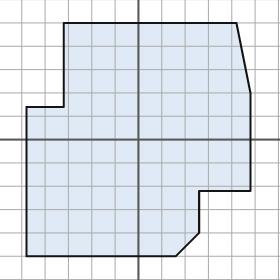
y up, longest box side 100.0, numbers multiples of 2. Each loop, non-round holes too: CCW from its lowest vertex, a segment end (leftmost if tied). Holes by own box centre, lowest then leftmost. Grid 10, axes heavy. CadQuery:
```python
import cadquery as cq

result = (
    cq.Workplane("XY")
    .moveTo(-48.0, -50.0)
    .lineTo(16.0, -50.0)
    .lineTo(26.0, -40.0)
    .lineTo(26.0, -22.0)
    .lineTo(48.0, -22.0)
    .lineTo(48.0, 20.0)
    .lineTo(42.0, 50.0)
    .lineTo(-32.0, 50.0)
    .lineTo(-32.0, 14.0)
    .lineTo(-48.0, 14.0)
    .close()
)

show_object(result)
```